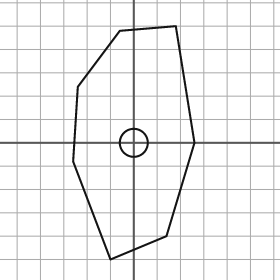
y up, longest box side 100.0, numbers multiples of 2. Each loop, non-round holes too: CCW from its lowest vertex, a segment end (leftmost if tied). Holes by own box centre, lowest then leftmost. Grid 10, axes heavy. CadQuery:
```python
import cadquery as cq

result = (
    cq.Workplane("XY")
    .moveTo(-10.0, -50.0)
    .lineTo(14.0, -40.0)
    .lineTo(26.0, 0.0)
    .lineTo(18.0, 50.0)
    .lineTo(-6.0, 48.0)
    .lineTo(-24.0, 24.0)
    .lineTo(-26.0, -8.0)
    .close()
    .moveTo(0.0, 0.0)
    .circle(6.0)
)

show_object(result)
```